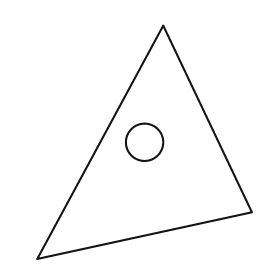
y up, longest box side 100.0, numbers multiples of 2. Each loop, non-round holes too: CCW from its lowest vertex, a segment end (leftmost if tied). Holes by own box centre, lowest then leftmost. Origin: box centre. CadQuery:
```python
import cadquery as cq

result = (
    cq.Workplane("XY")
    .moveTo(-46.0, -50.0)
    .lineTo(46.0, -30.0)
    .lineTo(8.0, 50.0)
    .close()
    .moveTo(0.0, 0.0)
    .circle(8.0)
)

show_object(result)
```